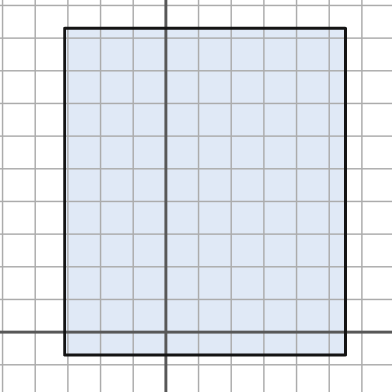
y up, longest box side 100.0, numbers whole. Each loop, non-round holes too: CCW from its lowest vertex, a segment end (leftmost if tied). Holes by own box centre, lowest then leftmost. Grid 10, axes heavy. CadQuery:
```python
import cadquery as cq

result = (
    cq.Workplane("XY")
    .moveTo(-31.0, -7.0)
    .lineTo(55.0, -7.0)
    .lineTo(55.0, 93.0)
    .lineTo(-31.0, 93.0)
    .close()
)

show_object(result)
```